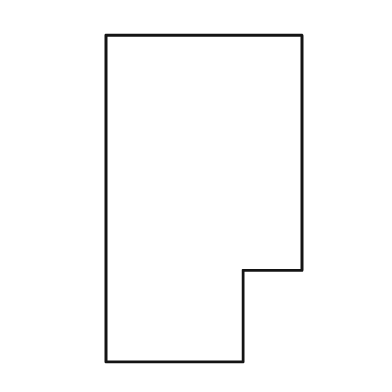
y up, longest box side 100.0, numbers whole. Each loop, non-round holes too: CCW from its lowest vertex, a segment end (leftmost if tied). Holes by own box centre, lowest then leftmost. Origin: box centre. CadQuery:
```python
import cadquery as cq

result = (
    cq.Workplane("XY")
    .moveTo(-30.0, -50.0)
    .lineTo(12.0, -50.0)
    .lineTo(12.0, -22.0)
    .lineTo(30.0, -22.0)
    .lineTo(30.0, 50.0)
    .lineTo(-30.0, 50.0)
    .close()
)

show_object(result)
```